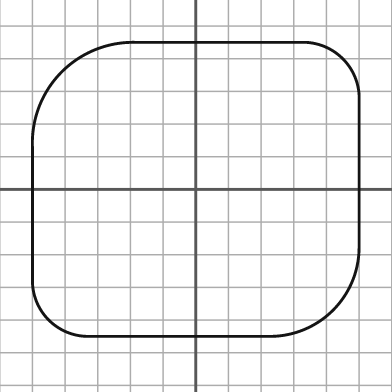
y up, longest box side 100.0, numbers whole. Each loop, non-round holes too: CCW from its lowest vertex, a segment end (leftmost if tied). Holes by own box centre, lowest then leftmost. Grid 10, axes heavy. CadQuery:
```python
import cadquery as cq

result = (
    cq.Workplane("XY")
    .moveTo(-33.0, -45.0)
    .lineTo(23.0, -45.0)
    .threePointArc((42.0, -37.0), (50.0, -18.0))
    .lineTo(50.0, 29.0)
    .threePointArc((45.0, 40.0), (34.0, 45.0))
    .lineTo(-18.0, 45.0)
    .threePointArc((-41.0, 36.0), (-50.0, 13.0))
    .lineTo(-50.0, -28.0)
    .threePointArc((-45.0, -40.0), (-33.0, -45.0))
    .close()
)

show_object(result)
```